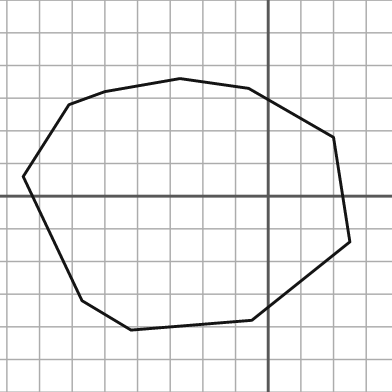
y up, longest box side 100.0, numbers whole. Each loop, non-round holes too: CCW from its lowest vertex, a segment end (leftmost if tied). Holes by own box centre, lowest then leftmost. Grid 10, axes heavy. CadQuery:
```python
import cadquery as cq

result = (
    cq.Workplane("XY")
    .moveTo(-42.0, -41.0)
    .lineTo(-5.0, -38.0)
    .lineTo(25.0, -14.0)
    .lineTo(20.0, 18.0)
    .lineTo(-6.0, 33.0)
    .lineTo(-27.0, 36.0)
    .lineTo(-50.0, 32.0)
    .lineTo(-61.0, 28.0)
    .lineTo(-75.0, 6.0)
    .lineTo(-57.0, -32.0)
    .close()
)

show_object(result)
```